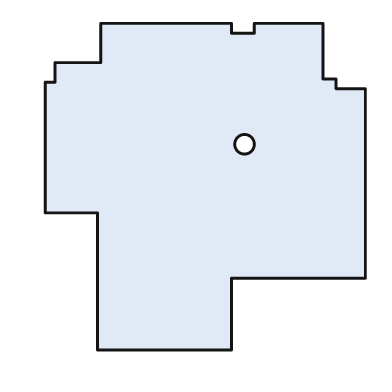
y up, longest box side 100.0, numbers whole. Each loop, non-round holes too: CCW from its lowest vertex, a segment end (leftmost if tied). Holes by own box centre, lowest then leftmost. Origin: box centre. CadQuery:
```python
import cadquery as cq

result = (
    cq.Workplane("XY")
    .moveTo(-33.0, -50.0)
    .lineTo(8.0, -50.0)
    .lineTo(8.0, -28.0)
    .lineTo(49.0, -28.0)
    .lineTo(49.0, 30.0)
    .lineTo(40.0, 30.0)
    .lineTo(40.0, 33.0)
    .lineTo(36.0, 33.0)
    .lineTo(36.0, 50.0)
    .lineTo(15.0, 50.0)
    .lineTo(15.0, 47.0)
    .lineTo(8.0, 47.0)
    .lineTo(8.0, 50.0)
    .lineTo(-32.0, 50.0)
    .lineTo(-32.0, 38.0)
    .lineTo(-46.0, 38.0)
    .lineTo(-46.0, 32.0)
    .lineTo(-49.0, 32.0)
    .lineTo(-49.0, -8.0)
    .lineTo(-33.0, -8.0)
    .close()
    .moveTo(12.0, 13.0)
    .circle(3.0)
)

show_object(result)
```